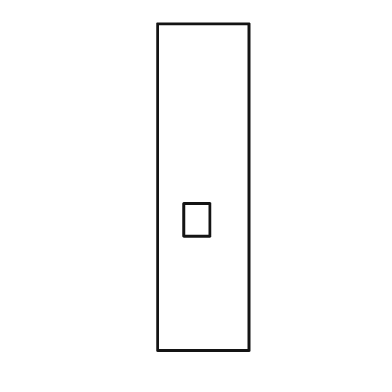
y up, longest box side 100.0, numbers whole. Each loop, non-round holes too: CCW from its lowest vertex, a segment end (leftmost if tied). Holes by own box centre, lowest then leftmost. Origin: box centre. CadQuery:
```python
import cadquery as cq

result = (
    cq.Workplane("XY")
    .moveTo(-14.0, -50.0)
    .lineTo(14.0, -50.0)
    .lineTo(14.0, 50.0)
    .lineTo(-14.0, 50.0)
    .close()
    .moveTo(-6.0, -15.0)
    .lineTo(2.0, -15.0)
    .lineTo(2.0, -5.0)
    .lineTo(-6.0, -5.0)
    .close()
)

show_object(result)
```